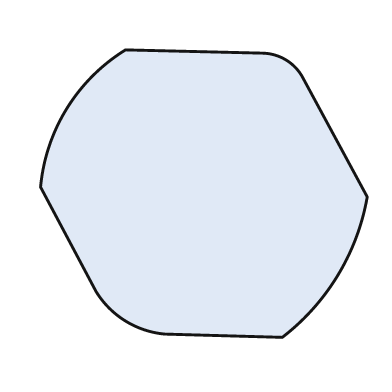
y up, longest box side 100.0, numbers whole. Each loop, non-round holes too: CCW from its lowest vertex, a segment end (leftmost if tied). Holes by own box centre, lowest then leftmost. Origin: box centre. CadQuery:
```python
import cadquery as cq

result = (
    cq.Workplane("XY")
    .moveTo(24.0, -44.0)
    .threePointArc((41.0, -25.0), (50.0, -1.0))
    .lineTo(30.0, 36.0)
    .threePointArc((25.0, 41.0), (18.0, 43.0))
    .lineTo(-24.0, 44.0)
    .threePointArc((-42.0, 26.0), (-50.0, 2.0))
    .lineTo(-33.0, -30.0)
    .threePointArc((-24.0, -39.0), (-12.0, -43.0))
    .close()
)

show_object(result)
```